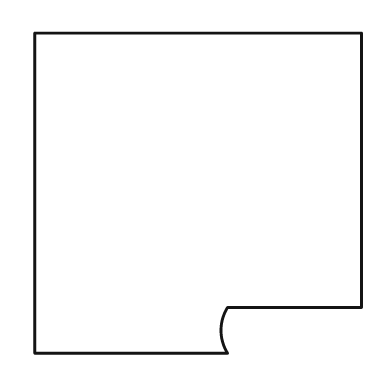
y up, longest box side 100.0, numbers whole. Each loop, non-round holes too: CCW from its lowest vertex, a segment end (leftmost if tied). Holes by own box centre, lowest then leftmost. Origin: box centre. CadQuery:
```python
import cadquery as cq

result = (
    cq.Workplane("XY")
    .moveTo(-50.0, -49.0)
    .lineTo(9.0, -49.0)
    .threePointArc((7.0, -42.0), (9.0, -35.0))
    .lineTo(50.0, -35.0)
    .lineTo(50.0, 49.0)
    .lineTo(-50.0, 49.0)
    .close()
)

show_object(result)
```